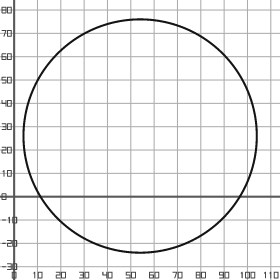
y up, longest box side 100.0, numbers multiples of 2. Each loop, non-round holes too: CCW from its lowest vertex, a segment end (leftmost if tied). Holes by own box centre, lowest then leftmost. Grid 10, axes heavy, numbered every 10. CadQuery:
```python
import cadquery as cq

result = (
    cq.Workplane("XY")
    .moveTo(54.0, 26.0)
    .circle(50.0)
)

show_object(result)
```